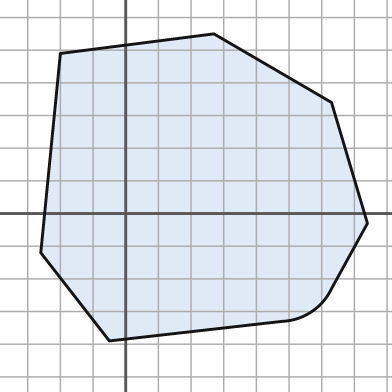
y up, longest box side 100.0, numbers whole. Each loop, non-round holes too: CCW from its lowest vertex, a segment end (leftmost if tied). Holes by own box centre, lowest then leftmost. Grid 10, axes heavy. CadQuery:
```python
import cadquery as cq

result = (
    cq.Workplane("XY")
    .moveTo(-5.0, -39.0)
    .lineTo(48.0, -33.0)
    .threePointArc((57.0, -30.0), (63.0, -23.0))
    .lineTo(74.0, -3.0)
    .lineTo(63.0, 34.0)
    .lineTo(27.0, 55.0)
    .lineTo(-20.0, 49.0)
    .lineTo(-26.0, -12.0)
    .close()
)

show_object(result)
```